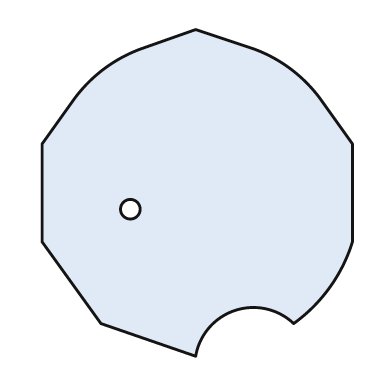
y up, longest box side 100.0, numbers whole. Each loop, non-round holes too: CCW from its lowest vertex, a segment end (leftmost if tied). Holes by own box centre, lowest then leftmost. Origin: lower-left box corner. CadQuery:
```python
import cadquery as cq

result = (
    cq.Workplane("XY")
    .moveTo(47.0, 0.0)
    .threePointArc((59.0, 14.0), (77.0, 10.0))
    .threePointArc((88.0, 21.0), (95.0, 35.0))
    .lineTo(95.0, 65.0)
    .lineTo(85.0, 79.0)
    .threePointArc((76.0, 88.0), (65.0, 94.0))
    .lineTo(47.0, 100.0)
    .lineTo(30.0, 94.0)
    .threePointArc((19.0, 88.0), (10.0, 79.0))
    .lineTo(0.0, 65.0)
    .lineTo(0.0, 35.0)
    .lineTo(18.0, 10.0)
    .close()
    .moveTo(27.0, 45.0)
    .circle(3.0)
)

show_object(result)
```